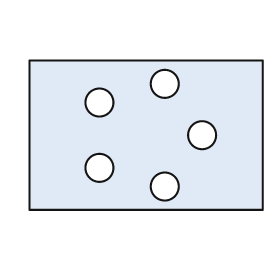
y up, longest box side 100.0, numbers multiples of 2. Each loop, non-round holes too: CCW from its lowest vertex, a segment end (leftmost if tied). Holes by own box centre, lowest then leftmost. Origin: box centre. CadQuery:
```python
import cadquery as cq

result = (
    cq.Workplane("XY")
    .moveTo(-50.0, -32.0)
    .lineTo(50.0, -32.0)
    .lineTo(50.0, 32.0)
    .lineTo(-50.0, 32.0)
    .close()
    .moveTo(8.0, -22.0)
    .circle(6.0)
    .moveTo(-20.0, -14.0)
    .circle(6.0)
    .moveTo(24.0, 0.0)
    .circle(6.0)
    .moveTo(-20.0, 14.0)
    .circle(6.0)
    .moveTo(8.0, 22.0)
    .circle(6.0)
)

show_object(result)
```